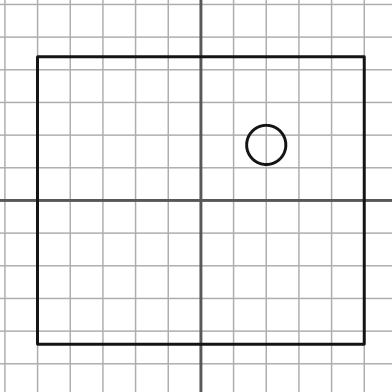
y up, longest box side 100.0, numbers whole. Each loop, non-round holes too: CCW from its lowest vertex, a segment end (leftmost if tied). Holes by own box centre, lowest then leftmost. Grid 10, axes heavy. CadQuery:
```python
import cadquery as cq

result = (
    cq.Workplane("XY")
    .moveTo(-50.0, -44.0)
    .lineTo(50.0, -44.0)
    .lineTo(50.0, 44.0)
    .lineTo(-50.0, 44.0)
    .close()
    .moveTo(20.0, 17.0)
    .circle(6.0)
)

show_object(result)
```